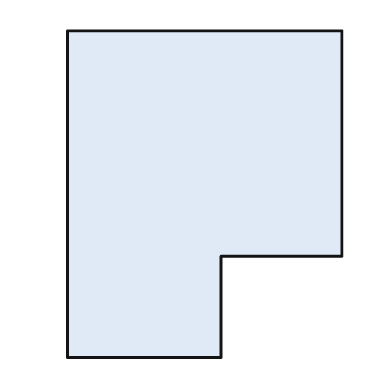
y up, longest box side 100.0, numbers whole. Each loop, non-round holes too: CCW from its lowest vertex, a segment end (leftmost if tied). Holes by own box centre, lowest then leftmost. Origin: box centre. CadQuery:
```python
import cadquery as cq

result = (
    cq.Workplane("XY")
    .moveTo(-42.0, -50.0)
    .lineTo(5.0, -50.0)
    .lineTo(5.0, -19.0)
    .lineTo(42.0, -19.0)
    .lineTo(42.0, 50.0)
    .lineTo(-42.0, 50.0)
    .close()
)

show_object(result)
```